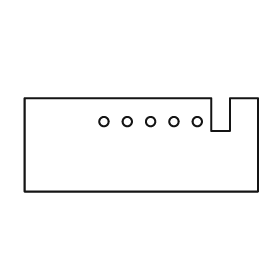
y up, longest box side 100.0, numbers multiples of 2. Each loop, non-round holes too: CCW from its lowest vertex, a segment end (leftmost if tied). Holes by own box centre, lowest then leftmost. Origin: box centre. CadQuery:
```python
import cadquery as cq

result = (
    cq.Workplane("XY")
    .moveTo(-50.0, -20.0)
    .lineTo(50.0, -20.0)
    .lineTo(50.0, 20.0)
    .lineTo(38.0, 20.0)
    .lineTo(38.0, 6.0)
    .lineTo(30.0, 6.0)
    .lineTo(30.0, 20.0)
    .lineTo(-50.0, 20.0)
    .close()
    .moveTo(-16.0, 10.0)
    .circle(2.0)
    .moveTo(-6.0, 10.0)
    .circle(2.0)
    .moveTo(4.0, 10.0)
    .circle(2.0)
    .moveTo(14.0, 10.0)
    .circle(2.0)
    .moveTo(24.0, 10.0)
    .circle(2.0)
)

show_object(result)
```